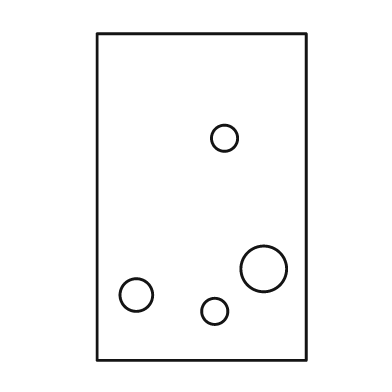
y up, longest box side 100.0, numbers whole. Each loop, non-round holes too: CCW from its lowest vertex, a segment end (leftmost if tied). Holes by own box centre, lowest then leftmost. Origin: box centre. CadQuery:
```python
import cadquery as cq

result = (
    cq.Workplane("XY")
    .moveTo(-32.0, -50.0)
    .lineTo(32.0, -50.0)
    .lineTo(32.0, 50.0)
    .lineTo(-32.0, 50.0)
    .close()
    .moveTo(4.0, -35.0)
    .circle(4.0)
    .moveTo(-20.0, -30.0)
    .circle(5.0)
    .moveTo(19.0, -22.0)
    .circle(7.0)
    .moveTo(7.0, 18.0)
    .circle(4.0)
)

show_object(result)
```